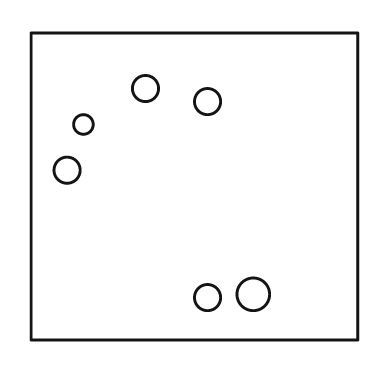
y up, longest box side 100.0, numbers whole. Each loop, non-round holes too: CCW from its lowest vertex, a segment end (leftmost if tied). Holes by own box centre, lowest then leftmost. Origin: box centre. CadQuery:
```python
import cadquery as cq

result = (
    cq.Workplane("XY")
    .moveTo(-50.0, -47.0)
    .lineTo(50.0, -47.0)
    .lineTo(50.0, 47.0)
    .lineTo(-50.0, 47.0)
    .close()
    .moveTo(4.0, -34.0)
    .circle(4.0)
    .moveTo(18.0, -33.0)
    .circle(5.0)
    .moveTo(-39.0, 5.0)
    .circle(4.0)
    .moveTo(-34.0, 19.0)
    .circle(3.0)
    .moveTo(4.0, 26.0)
    .circle(4.0)
    .moveTo(-15.0, 30.0)
    .circle(4.0)
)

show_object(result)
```